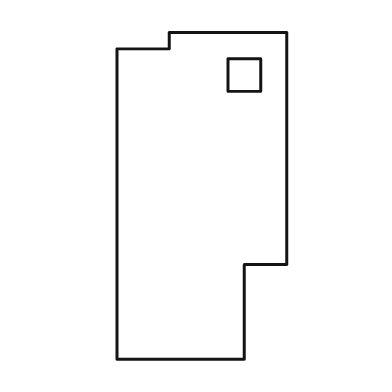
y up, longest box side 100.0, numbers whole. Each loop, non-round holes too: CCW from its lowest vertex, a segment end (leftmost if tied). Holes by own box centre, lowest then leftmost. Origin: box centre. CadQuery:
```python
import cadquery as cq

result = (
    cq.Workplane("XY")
    .moveTo(-26.0, -50.0)
    .lineTo(13.0, -50.0)
    .lineTo(13.0, -21.0)
    .lineTo(26.0, -21.0)
    .lineTo(26.0, 50.0)
    .lineTo(-10.0, 50.0)
    .lineTo(-10.0, 45.0)
    .lineTo(-26.0, 45.0)
    .close()
    .moveTo(8.0, 32.0)
    .lineTo(18.0, 32.0)
    .lineTo(18.0, 42.0)
    .lineTo(8.0, 42.0)
    .close()
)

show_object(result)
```